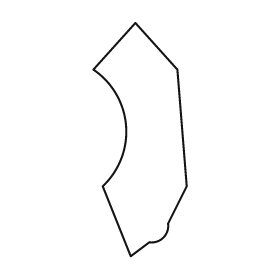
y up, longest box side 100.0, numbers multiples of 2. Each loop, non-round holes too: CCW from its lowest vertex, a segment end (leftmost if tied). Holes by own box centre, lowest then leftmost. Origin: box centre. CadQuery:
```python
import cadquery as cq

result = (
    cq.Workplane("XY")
    .moveTo(-4.0, -50.0)
    .lineTo(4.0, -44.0)
    .threePointArc((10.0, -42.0), (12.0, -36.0))
    .lineTo(20.0, -20.0)
    .lineTo(16.0, 30.0)
    .lineTo(-2.0, 50.0)
    .lineTo(-20.0, 30.0)
    .threePointArc((-6.0, 6.0), (-16.0, -20.0))
    .close()
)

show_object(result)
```